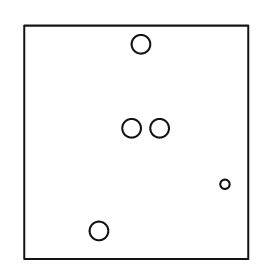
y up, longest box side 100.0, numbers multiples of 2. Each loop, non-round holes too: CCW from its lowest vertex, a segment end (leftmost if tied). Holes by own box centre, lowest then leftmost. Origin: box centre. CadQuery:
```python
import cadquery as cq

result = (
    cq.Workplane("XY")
    .moveTo(-48.0, -50.0)
    .lineTo(48.0, -50.0)
    .lineTo(48.0, 50.0)
    .lineTo(-48.0, 50.0)
    .close()
    .moveTo(-16.0, -38.0)
    .circle(4.0)
    .moveTo(38.0, -18.0)
    .circle(2.0)
    .moveTo(-2.0, 6.0)
    .circle(4.0)
    .moveTo(10.0, 6.0)
    .circle(4.0)
    .moveTo(2.0, 42.0)
    .circle(4.0)
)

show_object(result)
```